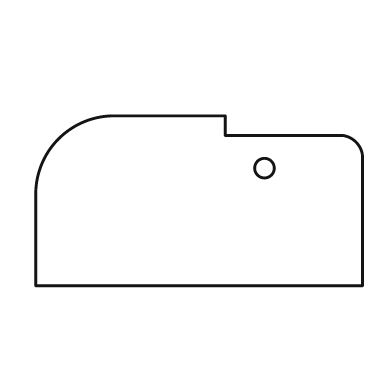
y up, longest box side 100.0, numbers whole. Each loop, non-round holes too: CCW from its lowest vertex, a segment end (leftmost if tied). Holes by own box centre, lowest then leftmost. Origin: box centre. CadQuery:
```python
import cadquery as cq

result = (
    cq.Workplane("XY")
    .moveTo(-50.0, -26.0)
    .lineTo(50.0, -26.0)
    .lineTo(50.0, 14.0)
    .threePointArc((48.0, 18.0), (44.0, 20.0))
    .lineTo(8.0, 20.0)
    .lineTo(8.0, 26.0)
    .lineTo(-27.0, 26.0)
    .threePointArc((-43.0, 19.0), (-50.0, 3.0))
    .close()
    .moveTo(20.0, 10.0)
    .circle(3.0)
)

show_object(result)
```